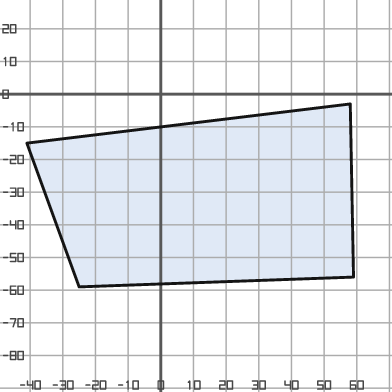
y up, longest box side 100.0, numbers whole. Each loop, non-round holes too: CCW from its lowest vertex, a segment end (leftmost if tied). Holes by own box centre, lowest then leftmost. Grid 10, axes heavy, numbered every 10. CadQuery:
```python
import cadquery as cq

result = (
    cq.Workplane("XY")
    .moveTo(-25.0, -59.0)
    .lineTo(59.0, -56.0)
    .lineTo(58.0, -3.0)
    .lineTo(-41.0, -15.0)
    .close()
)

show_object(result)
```